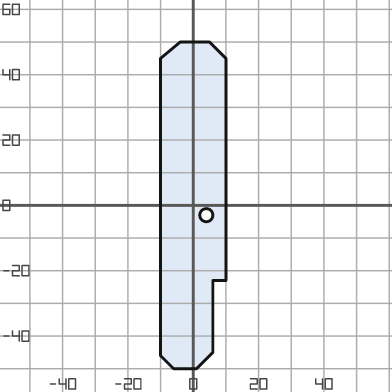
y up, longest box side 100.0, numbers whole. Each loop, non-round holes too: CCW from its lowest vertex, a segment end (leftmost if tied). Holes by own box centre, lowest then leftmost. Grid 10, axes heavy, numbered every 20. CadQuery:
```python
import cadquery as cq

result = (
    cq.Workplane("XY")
    .moveTo(-6.0, -50.0)
    .lineTo(1.0, -50.0)
    .lineTo(6.0, -45.0)
    .lineTo(6.0, -23.0)
    .lineTo(10.0, -23.0)
    .lineTo(10.0, 45.0)
    .lineTo(5.0, 50.0)
    .lineTo(-4.0, 50.0)
    .lineTo(-10.0, 45.0)
    .lineTo(-10.0, -46.0)
    .close()
    .moveTo(4.0, -3.0)
    .circle(2.0)
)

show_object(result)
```